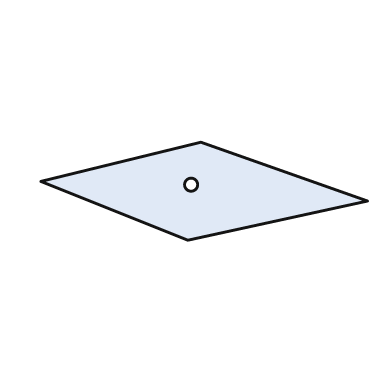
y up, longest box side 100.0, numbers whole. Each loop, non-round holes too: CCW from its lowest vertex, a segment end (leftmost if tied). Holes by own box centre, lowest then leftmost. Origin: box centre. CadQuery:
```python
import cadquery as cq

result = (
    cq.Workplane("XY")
    .moveTo(-5.0, -15.0)
    .lineTo(50.0, -3.0)
    .lineTo(-1.0, 15.0)
    .lineTo(-50.0, 3.0)
    .close()
    .moveTo(-4.0, 2.0)
    .circle(2.0)
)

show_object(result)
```